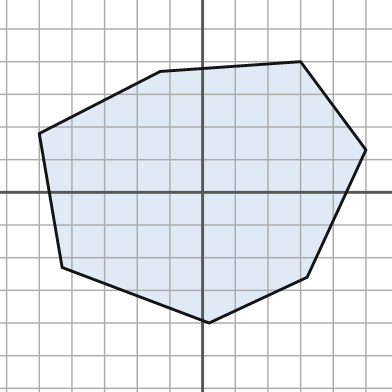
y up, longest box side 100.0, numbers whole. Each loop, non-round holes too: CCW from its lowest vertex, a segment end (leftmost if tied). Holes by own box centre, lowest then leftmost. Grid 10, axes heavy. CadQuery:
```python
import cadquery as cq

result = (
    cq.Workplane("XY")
    .moveTo(2.0, -40.0)
    .lineTo(32.0, -26.0)
    .lineTo(50.0, 13.0)
    .lineTo(30.0, 40.0)
    .lineTo(-13.0, 37.0)
    .lineTo(-50.0, 18.0)
    .lineTo(-43.0, -23.0)
    .close()
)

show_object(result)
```